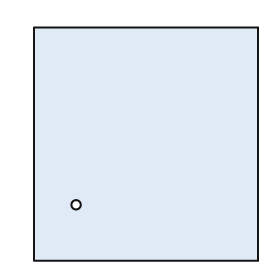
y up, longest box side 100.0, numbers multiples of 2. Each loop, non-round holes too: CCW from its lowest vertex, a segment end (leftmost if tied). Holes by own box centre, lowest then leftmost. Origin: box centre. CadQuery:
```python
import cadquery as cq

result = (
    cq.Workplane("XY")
    .moveTo(-48.0, -50.0)
    .lineTo(48.0, -50.0)
    .lineTo(48.0, 50.0)
    .lineTo(-48.0, 50.0)
    .close()
    .moveTo(-30.0, -26.0)
    .circle(2.0)
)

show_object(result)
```